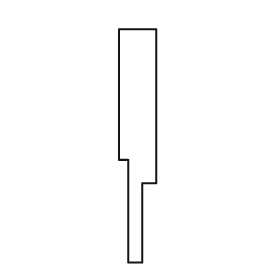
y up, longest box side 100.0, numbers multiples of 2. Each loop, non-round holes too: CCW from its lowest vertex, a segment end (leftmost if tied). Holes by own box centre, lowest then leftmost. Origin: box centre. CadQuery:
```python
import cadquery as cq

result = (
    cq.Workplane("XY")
    .moveTo(-4.0, -50.0)
    .lineTo(2.0, -50.0)
    .lineTo(2.0, -16.0)
    .lineTo(8.0, -16.0)
    .lineTo(8.0, 50.0)
    .lineTo(-8.0, 50.0)
    .lineTo(-8.0, -6.0)
    .lineTo(-4.0, -6.0)
    .close()
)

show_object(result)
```